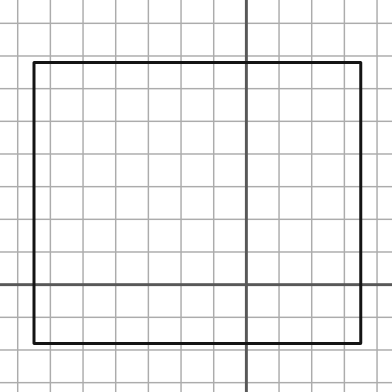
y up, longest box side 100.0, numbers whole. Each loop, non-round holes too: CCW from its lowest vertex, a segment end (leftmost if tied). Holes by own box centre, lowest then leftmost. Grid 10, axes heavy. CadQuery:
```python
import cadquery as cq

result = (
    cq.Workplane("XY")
    .moveTo(-65.0, -18.0)
    .lineTo(35.0, -18.0)
    .lineTo(35.0, 68.0)
    .lineTo(-65.0, 68.0)
    .close()
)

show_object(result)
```